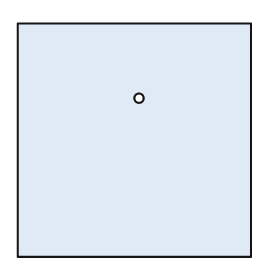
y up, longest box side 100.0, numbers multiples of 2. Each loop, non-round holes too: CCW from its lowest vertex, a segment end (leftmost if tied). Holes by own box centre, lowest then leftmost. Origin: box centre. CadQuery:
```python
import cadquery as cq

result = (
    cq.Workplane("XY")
    .moveTo(-50.0, -50.0)
    .lineTo(50.0, -50.0)
    .lineTo(50.0, 50.0)
    .lineTo(-50.0, 50.0)
    .close()
    .moveTo(2.0, 18.0)
    .circle(2.0)
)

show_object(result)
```